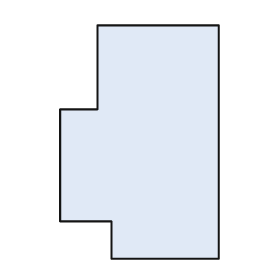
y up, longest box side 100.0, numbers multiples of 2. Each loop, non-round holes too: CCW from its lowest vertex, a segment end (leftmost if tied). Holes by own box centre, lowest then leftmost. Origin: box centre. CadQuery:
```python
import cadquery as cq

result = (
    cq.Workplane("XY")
    .moveTo(-12.0, -50.0)
    .lineTo(34.0, -50.0)
    .lineTo(34.0, 50.0)
    .lineTo(-18.0, 50.0)
    .lineTo(-18.0, 14.0)
    .lineTo(-34.0, 14.0)
    .lineTo(-34.0, -34.0)
    .lineTo(-12.0, -34.0)
    .close()
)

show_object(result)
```